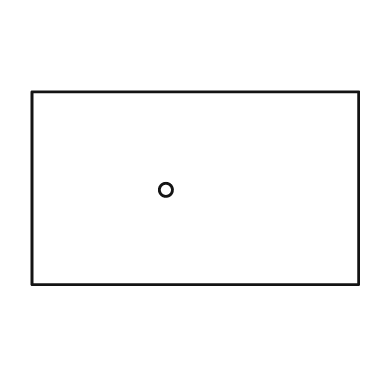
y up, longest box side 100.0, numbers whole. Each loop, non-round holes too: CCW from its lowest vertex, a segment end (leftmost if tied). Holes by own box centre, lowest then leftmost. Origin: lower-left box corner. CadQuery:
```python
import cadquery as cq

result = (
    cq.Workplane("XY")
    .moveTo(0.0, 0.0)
    .lineTo(100.0, 0.0)
    .lineTo(100.0, 59.0)
    .lineTo(0.0, 59.0)
    .close()
    .moveTo(41.0, 29.0)
    .circle(2.0)
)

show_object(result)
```